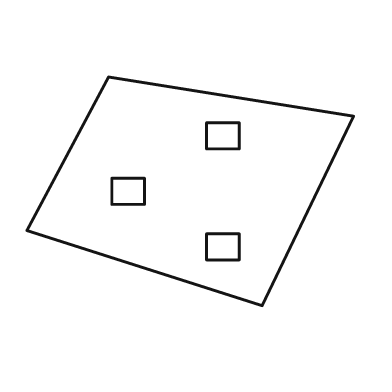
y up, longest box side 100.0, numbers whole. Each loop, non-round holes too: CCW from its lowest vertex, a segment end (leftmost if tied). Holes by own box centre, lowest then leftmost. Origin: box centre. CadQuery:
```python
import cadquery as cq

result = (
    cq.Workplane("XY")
    .moveTo(22.0, -35.0)
    .lineTo(50.0, 23.0)
    .lineTo(-25.0, 35.0)
    .lineTo(-50.0, -12.0)
    .close()
    .moveTo(5.0, -21.0)
    .lineTo(15.0, -21.0)
    .lineTo(15.0, -13.0)
    .lineTo(5.0, -13.0)
    .close()
    .moveTo(-24.0, -4.0)
    .lineTo(-14.0, -4.0)
    .lineTo(-14.0, 4.0)
    .lineTo(-24.0, 4.0)
    .close()
    .moveTo(5.0, 13.0)
    .lineTo(15.0, 13.0)
    .lineTo(15.0, 21.0)
    .lineTo(5.0, 21.0)
    .close()
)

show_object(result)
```